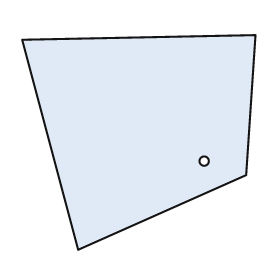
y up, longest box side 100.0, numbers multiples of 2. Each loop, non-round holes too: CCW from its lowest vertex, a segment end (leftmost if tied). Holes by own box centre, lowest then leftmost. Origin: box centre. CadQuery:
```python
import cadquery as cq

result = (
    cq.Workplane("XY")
    .moveTo(-26.0, -46.0)
    .lineTo(46.0, -14.0)
    .lineTo(50.0, 46.0)
    .lineTo(-50.0, 44.0)
    .close()
    .moveTo(28.0, -8.0)
    .circle(2.0)
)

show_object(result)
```